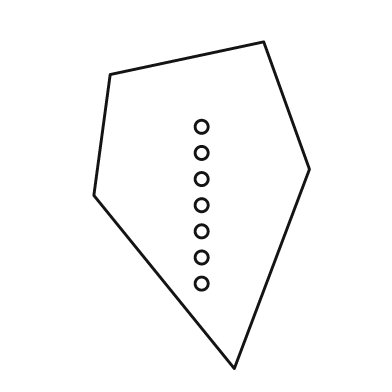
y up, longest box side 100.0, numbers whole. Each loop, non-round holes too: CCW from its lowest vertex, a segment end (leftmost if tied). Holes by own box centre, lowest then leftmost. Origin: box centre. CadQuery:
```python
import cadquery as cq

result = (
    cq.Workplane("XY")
    .moveTo(10.0, -50.0)
    .lineTo(33.0, 11.0)
    .lineTo(19.0, 50.0)
    .lineTo(-28.0, 40.0)
    .lineTo(-33.0, 3.0)
    .close()
    .moveTo(0.0, -24.0)
    .circle(2.0)
    .moveTo(0.0, -16.0)
    .circle(2.0)
    .moveTo(0.0, -8.0)
    .circle(2.0)
    .moveTo(0.0, 0.0)
    .circle(2.0)
    .moveTo(0.0, 8.0)
    .circle(2.0)
    .moveTo(0.0, 16.0)
    .circle(2.0)
    .moveTo(0.0, 24.0)
    .circle(2.0)
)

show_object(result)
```